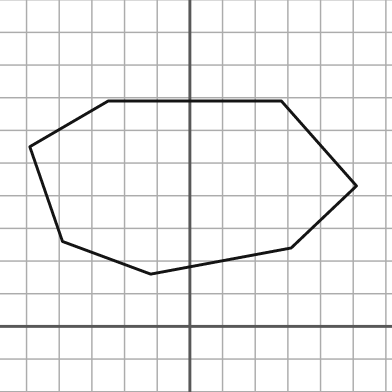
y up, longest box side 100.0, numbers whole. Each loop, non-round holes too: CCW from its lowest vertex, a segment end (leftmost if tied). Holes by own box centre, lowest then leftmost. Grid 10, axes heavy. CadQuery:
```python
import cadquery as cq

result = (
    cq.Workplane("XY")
    .moveTo(-12.0, 16.0)
    .lineTo(31.0, 24.0)
    .lineTo(51.0, 43.0)
    .lineTo(28.0, 69.0)
    .lineTo(-25.0, 69.0)
    .lineTo(-49.0, 55.0)
    .lineTo(-39.0, 26.0)
    .close()
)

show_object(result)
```